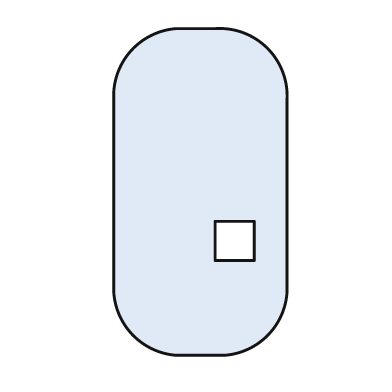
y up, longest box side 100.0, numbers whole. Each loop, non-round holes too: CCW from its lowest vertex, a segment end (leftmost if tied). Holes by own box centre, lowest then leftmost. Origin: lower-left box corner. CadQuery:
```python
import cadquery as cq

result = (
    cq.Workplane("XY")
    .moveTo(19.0, 0.0)
    .lineTo(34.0, 0.0)
    .threePointArc((47.0, 6.0), (53.0, 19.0))
    .lineTo(53.0, 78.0)
    .threePointArc((47.0, 94.0), (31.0, 100.0))
    .lineTo(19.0, 100.0)
    .threePointArc((6.0, 94.0), (0.0, 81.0))
    .lineTo(0.0, 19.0)
    .threePointArc((6.0, 6.0), (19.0, 0.0))
    .close()
    .moveTo(31.0, 29.0)
    .lineTo(43.0, 29.0)
    .lineTo(43.0, 41.0)
    .lineTo(31.0, 41.0)
    .close()
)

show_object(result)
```